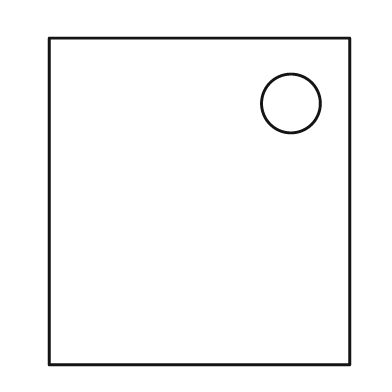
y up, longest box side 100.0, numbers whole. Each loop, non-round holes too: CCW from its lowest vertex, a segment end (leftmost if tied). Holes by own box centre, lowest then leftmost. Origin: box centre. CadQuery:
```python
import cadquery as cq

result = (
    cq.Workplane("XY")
    .moveTo(-46.0, -50.0)
    .lineTo(46.0, -50.0)
    .lineTo(46.0, 50.0)
    .lineTo(-46.0, 50.0)
    .close()
    .moveTo(28.0, 30.0)
    .circle(9.0)
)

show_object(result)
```